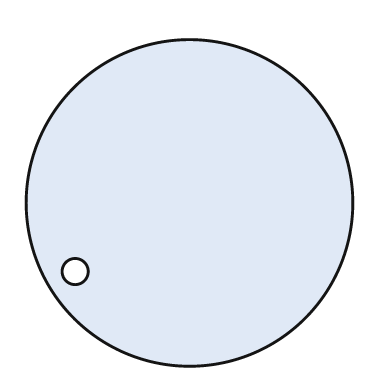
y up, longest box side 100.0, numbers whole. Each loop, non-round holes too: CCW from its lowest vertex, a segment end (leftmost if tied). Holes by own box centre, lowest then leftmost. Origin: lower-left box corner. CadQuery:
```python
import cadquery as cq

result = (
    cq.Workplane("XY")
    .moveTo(50.0, 50.0)
    .circle(50.0)
    .moveTo(15.0, 29.0)
    .circle(4.0)
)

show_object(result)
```